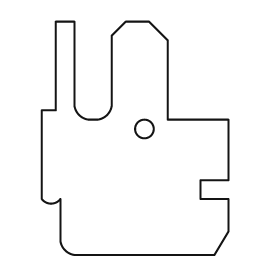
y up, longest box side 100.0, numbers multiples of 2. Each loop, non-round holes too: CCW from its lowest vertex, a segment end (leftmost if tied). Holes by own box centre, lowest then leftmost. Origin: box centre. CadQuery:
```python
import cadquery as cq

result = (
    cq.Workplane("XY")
    .moveTo(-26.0, -50.0)
    .lineTo(34.0, -50.0)
    .lineTo(40.0, -40.0)
    .lineTo(40.0, -26.0)
    .lineTo(28.0, -26.0)
    .lineTo(28.0, -18.0)
    .lineTo(40.0, -18.0)
    .lineTo(40.0, 8.0)
    .lineTo(14.0, 8.0)
    .lineTo(14.0, 42.0)
    .lineTo(6.0, 50.0)
    .lineTo(-4.0, 50.0)
    .lineTo(-10.0, 44.0)
    .lineTo(-10.0, 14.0)
    .threePointArc((-12.0, 10.0), (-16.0, 8.0))
    .lineTo(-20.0, 8.0)
    .threePointArc((-24.0, 10.0), (-26.0, 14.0))
    .lineTo(-26.0, 50.0)
    .lineTo(-34.0, 50.0)
    .lineTo(-34.0, 12.0)
    .lineTo(-40.0, 12.0)
    .lineTo(-40.0, -26.0)
    .threePointArc((-36.0, -28.0), (-32.0, -26.0))
    .lineTo(-32.0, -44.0)
    .threePointArc((-30.0, -48.0), (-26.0, -50.0))
    .close()
    .moveTo(4.0, 4.0)
    .circle(4.0)
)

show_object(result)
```